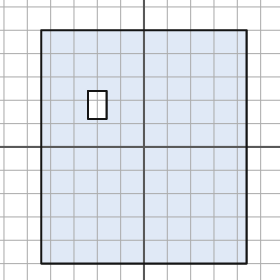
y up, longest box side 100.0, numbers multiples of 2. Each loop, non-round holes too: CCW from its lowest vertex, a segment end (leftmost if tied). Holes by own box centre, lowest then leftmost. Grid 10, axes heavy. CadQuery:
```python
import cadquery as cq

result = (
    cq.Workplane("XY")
    .moveTo(-44.0, -50.0)
    .lineTo(44.0, -50.0)
    .lineTo(44.0, 50.0)
    .lineTo(-44.0, 50.0)
    .close()
    .moveTo(-24.0, 12.0)
    .lineTo(-16.0, 12.0)
    .lineTo(-16.0, 24.0)
    .lineTo(-24.0, 24.0)
    .close()
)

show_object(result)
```